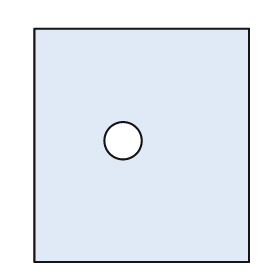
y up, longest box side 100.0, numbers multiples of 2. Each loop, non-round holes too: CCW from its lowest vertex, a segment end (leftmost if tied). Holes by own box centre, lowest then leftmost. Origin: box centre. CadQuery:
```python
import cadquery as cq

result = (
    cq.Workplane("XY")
    .moveTo(-46.0, -50.0)
    .lineTo(46.0, -50.0)
    .lineTo(46.0, 50.0)
    .lineTo(-46.0, 50.0)
    .close()
    .moveTo(-8.0, 2.0)
    .circle(8.0)
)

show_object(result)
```